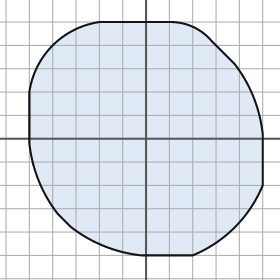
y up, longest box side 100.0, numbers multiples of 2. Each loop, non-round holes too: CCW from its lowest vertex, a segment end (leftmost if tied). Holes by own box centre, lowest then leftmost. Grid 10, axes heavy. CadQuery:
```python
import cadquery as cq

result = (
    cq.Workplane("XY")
    .moveTo(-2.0, -50.0)
    .lineTo(20.0, -50.0)
    .threePointArc((38.0, -38.0), (50.0, -20.0))
    .lineTo(50.0, 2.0)
    .threePointArc((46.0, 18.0), (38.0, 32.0))
    .lineTo(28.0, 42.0)
    .threePointArc((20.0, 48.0), (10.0, 50.0))
    .lineTo(-20.0, 50.0)
    .threePointArc((-40.0, 40.0), (-50.0, 20.0))
    .lineTo(-50.0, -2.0)
    .threePointArc((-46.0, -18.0), (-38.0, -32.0))
    .lineTo(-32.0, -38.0)
    .threePointArc((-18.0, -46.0), (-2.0, -50.0))
    .close()
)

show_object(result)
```